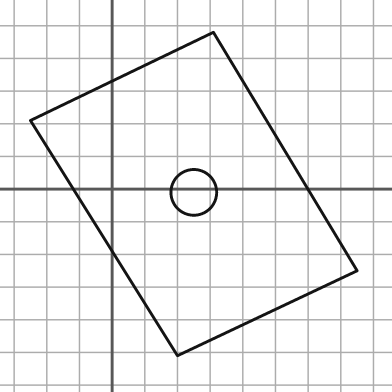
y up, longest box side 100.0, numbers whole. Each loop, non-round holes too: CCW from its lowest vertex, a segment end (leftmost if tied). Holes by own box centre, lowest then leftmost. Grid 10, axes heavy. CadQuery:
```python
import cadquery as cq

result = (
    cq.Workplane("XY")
    .moveTo(20.0, -51.0)
    .lineTo(75.0, -25.0)
    .lineTo(31.0, 48.0)
    .lineTo(-25.0, 21.0)
    .close()
    .moveTo(25.0, -1.0)
    .circle(7.0)
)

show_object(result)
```